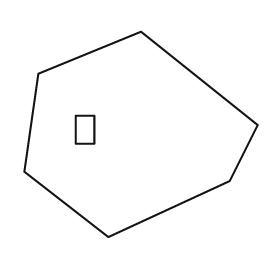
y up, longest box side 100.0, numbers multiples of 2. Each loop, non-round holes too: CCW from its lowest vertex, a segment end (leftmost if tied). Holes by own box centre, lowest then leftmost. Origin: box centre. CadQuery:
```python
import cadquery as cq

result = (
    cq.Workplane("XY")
    .moveTo(-14.0, -44.0)
    .lineTo(38.0, -20.0)
    .lineTo(50.0, 4.0)
    .lineTo(0.0, 44.0)
    .lineTo(-44.0, 26.0)
    .lineTo(-50.0, -16.0)
    .close()
    .moveTo(-28.0, -4.0)
    .lineTo(-20.0, -4.0)
    .lineTo(-20.0, 8.0)
    .lineTo(-28.0, 8.0)
    .close()
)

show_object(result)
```